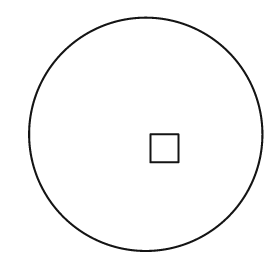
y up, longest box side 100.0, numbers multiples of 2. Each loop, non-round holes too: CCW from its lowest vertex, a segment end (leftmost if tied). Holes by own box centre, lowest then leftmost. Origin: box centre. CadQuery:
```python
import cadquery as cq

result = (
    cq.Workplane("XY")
    .moveTo(0.0, 0.0)
    .circle(50.0)
    .moveTo(2.0, -12.0)
    .lineTo(14.0, -12.0)
    .lineTo(14.0, 0.0)
    .lineTo(2.0, 0.0)
    .close()
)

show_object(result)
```